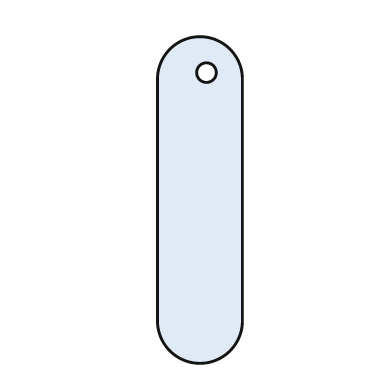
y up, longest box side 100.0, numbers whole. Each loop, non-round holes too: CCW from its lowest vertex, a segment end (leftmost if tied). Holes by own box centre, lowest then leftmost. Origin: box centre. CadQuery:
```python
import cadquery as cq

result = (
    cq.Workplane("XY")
    .moveTo(-13.0, -37.0)
    .threePointArc((0.0, -50.0), (13.0, -37.0))
    .lineTo(13.0, 37.0)
    .threePointArc((0.0, 50.0), (-13.0, 37.0))
    .close()
    .moveTo(2.0, 39.0)
    .circle(3.0)
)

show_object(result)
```